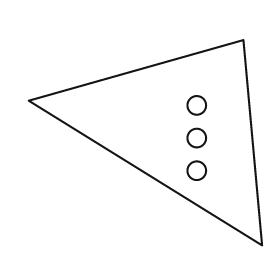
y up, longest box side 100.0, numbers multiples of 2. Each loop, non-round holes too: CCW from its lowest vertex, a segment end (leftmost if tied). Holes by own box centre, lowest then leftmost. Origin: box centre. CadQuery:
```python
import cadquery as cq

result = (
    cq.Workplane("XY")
    .moveTo(50.0, -44.0)
    .lineTo(42.0, 44.0)
    .lineTo(-50.0, 18.0)
    .close()
    .moveTo(22.0, -12.0)
    .circle(4.0)
    .moveTo(22.0, 2.0)
    .circle(4.0)
    .moveTo(22.0, 16.0)
    .circle(4.0)
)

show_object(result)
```